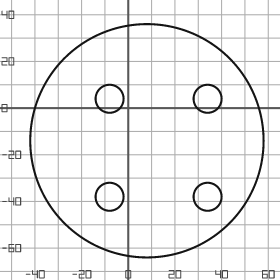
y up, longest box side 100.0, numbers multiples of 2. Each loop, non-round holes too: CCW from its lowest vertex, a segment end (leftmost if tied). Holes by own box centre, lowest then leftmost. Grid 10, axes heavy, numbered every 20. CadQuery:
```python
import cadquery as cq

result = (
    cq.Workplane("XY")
    .moveTo(8.0, -14.0)
    .circle(50.0)
    .moveTo(-8.0, -38.0)
    .circle(6.0)
    .moveTo(34.0, -38.0)
    .circle(6.0)
    .moveTo(-8.0, 4.0)
    .circle(6.0)
    .moveTo(34.0, 4.0)
    .circle(6.0)
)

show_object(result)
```